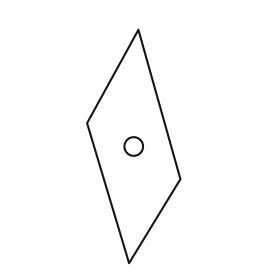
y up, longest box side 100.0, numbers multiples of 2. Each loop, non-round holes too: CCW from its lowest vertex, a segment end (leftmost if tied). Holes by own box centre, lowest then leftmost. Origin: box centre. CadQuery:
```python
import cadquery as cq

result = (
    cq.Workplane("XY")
    .moveTo(-2.0, -50.0)
    .lineTo(20.0, -14.0)
    .lineTo(2.0, 50.0)
    .lineTo(-20.0, 10.0)
    .close()
    .moveTo(0.0, 0.0)
    .circle(4.0)
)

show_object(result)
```